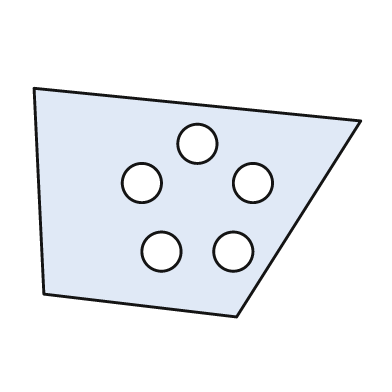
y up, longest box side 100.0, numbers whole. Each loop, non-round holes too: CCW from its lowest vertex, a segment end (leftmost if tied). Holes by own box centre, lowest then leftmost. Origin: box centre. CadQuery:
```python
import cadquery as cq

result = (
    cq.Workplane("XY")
    .moveTo(12.0, -35.0)
    .lineTo(50.0, 25.0)
    .lineTo(-50.0, 35.0)
    .lineTo(-47.0, -28.0)
    .close()
    .moveTo(-11.0, -15.0)
    .circle(6.0)
    .moveTo(11.0, -15.0)
    .circle(6.0)
    .moveTo(-17.0, 6.0)
    .circle(6.0)
    .moveTo(17.0, 6.0)
    .circle(6.0)
    .moveTo(0.0, 18.0)
    .circle(6.0)
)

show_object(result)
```